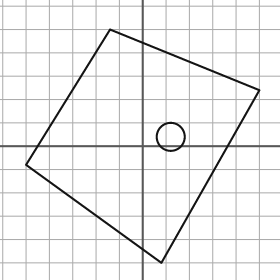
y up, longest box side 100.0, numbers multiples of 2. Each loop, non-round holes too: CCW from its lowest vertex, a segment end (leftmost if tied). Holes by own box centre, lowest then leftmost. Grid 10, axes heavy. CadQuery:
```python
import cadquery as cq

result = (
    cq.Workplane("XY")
    .moveTo(8.0, -50.0)
    .lineTo(50.0, 24.0)
    .lineTo(-14.0, 50.0)
    .lineTo(-50.0, -8.0)
    .close()
    .moveTo(12.0, 4.0)
    .circle(6.0)
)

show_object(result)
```